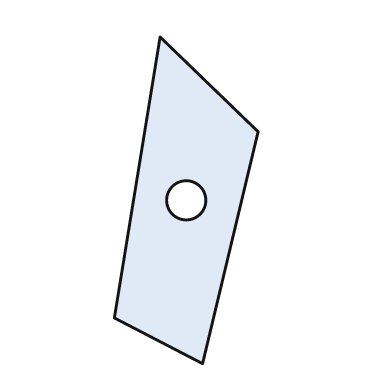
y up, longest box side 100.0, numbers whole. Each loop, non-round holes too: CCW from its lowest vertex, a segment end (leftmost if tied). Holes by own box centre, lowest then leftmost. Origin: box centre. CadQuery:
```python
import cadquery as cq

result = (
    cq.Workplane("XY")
    .moveTo(5.0, -50.0)
    .lineTo(22.0, 21.0)
    .lineTo(-8.0, 50.0)
    .lineTo(-22.0, -36.0)
    .close()
    .moveTo(0.0, 0.0)
    .circle(6.0)
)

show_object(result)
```